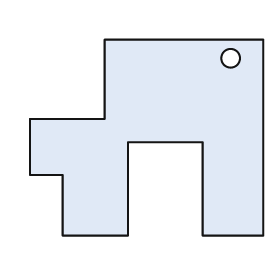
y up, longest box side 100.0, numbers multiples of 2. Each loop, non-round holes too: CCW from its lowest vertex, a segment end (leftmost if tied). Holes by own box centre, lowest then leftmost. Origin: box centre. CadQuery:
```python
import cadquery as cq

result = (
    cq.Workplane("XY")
    .moveTo(-36.0, -42.0)
    .lineTo(-8.0, -42.0)
    .lineTo(-8.0, -2.0)
    .lineTo(24.0, -2.0)
    .lineTo(24.0, -42.0)
    .lineTo(50.0, -42.0)
    .lineTo(50.0, 42.0)
    .lineTo(-18.0, 42.0)
    .lineTo(-18.0, 8.0)
    .lineTo(-50.0, 8.0)
    .lineTo(-50.0, -16.0)
    .lineTo(-36.0, -16.0)
    .close()
    .moveTo(36.0, 34.0)
    .circle(4.0)
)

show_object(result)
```